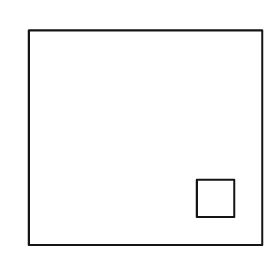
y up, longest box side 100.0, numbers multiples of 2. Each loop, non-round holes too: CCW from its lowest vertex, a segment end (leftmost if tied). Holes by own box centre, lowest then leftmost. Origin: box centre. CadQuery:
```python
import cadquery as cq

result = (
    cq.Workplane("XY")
    .moveTo(-50.0, -46.0)
    .lineTo(50.0, -46.0)
    .lineTo(50.0, 46.0)
    .lineTo(-50.0, 46.0)
    .close()
    .moveTo(22.0, -34.0)
    .lineTo(38.0, -34.0)
    .lineTo(38.0, -18.0)
    .lineTo(22.0, -18.0)
    .close()
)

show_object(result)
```